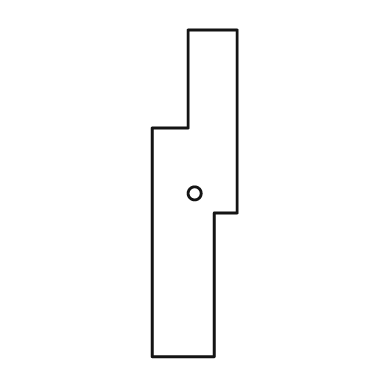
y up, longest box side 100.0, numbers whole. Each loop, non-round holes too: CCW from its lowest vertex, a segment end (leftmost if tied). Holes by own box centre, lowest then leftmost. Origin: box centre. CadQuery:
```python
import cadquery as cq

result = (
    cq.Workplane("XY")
    .moveTo(-13.0, -50.0)
    .lineTo(6.0, -50.0)
    .lineTo(6.0, -6.0)
    .lineTo(13.0, -6.0)
    .lineTo(13.0, 50.0)
    .lineTo(-2.0, 50.0)
    .lineTo(-2.0, 20.0)
    .lineTo(-13.0, 20.0)
    .close()
    .moveTo(0.0, 0.0)
    .circle(2.0)
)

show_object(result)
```